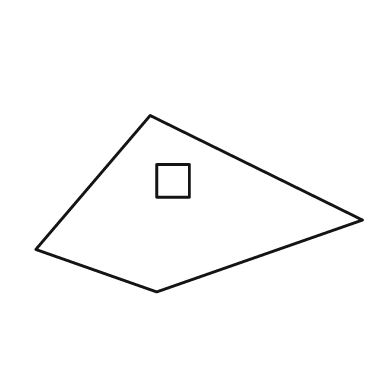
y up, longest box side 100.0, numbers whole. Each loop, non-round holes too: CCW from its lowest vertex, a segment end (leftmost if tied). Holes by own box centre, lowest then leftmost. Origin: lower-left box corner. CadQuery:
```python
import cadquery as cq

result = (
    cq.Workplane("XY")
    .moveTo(37.0, 0.0)
    .lineTo(100.0, 22.0)
    .lineTo(35.0, 54.0)
    .lineTo(0.0, 13.0)
    .close()
    .moveTo(37.0, 29.0)
    .lineTo(47.0, 29.0)
    .lineTo(47.0, 39.0)
    .lineTo(37.0, 39.0)
    .close()
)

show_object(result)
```